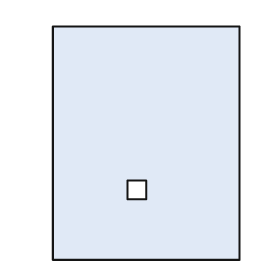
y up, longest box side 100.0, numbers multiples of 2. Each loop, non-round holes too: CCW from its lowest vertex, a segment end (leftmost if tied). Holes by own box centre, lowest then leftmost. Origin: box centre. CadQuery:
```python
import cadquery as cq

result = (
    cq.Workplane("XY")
    .moveTo(-40.0, -50.0)
    .lineTo(40.0, -50.0)
    .lineTo(40.0, 50.0)
    .lineTo(-40.0, 50.0)
    .close()
    .moveTo(-8.0, -24.0)
    .lineTo(0.0, -24.0)
    .lineTo(0.0, -16.0)
    .lineTo(-8.0, -16.0)
    .close()
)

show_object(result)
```